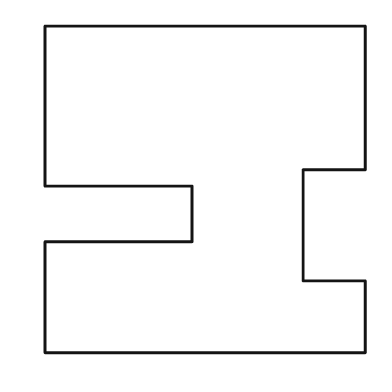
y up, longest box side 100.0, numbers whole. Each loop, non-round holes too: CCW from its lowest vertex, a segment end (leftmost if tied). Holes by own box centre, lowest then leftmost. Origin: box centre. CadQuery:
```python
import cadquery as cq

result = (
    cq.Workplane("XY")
    .moveTo(-49.0, -50.0)
    .lineTo(49.0, -50.0)
    .lineTo(49.0, -28.0)
    .lineTo(30.0, -28.0)
    .lineTo(30.0, 6.0)
    .lineTo(49.0, 6.0)
    .lineTo(49.0, 50.0)
    .lineTo(-49.0, 50.0)
    .lineTo(-49.0, 1.0)
    .lineTo(-4.0, 1.0)
    .lineTo(-4.0, -16.0)
    .lineTo(-49.0, -16.0)
    .close()
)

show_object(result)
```